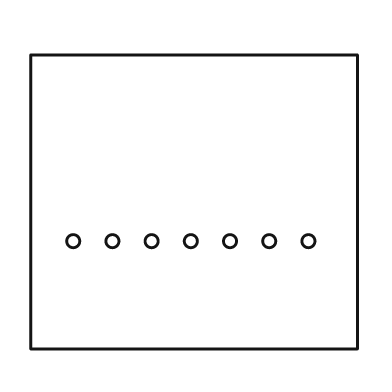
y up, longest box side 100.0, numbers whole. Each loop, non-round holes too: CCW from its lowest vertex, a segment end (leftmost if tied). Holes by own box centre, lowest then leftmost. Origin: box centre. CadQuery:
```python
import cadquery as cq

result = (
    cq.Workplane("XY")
    .moveTo(-50.0, -45.0)
    .lineTo(50.0, -45.0)
    .lineTo(50.0, 45.0)
    .lineTo(-50.0, 45.0)
    .close()
    .moveTo(-37.0, -12.0)
    .circle(2.0)
    .moveTo(-25.0, -12.0)
    .circle(2.0)
    .moveTo(-13.0, -12.0)
    .circle(2.0)
    .moveTo(-1.0, -12.0)
    .circle(2.0)
    .moveTo(11.0, -12.0)
    .circle(2.0)
    .moveTo(23.0, -12.0)
    .circle(2.0)
    .moveTo(35.0, -12.0)
    .circle(2.0)
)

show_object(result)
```